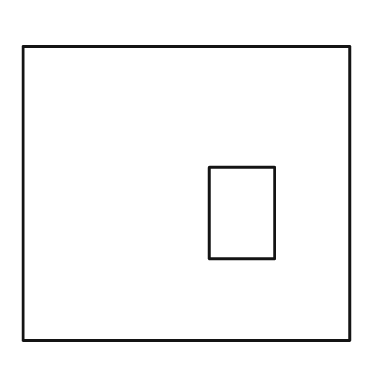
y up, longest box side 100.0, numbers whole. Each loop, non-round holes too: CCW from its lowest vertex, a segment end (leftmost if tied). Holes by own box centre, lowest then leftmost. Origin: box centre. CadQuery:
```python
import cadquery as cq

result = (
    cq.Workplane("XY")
    .moveTo(-50.0, -45.0)
    .lineTo(50.0, -45.0)
    .lineTo(50.0, 45.0)
    .lineTo(-50.0, 45.0)
    .close()
    .moveTo(7.0, -20.0)
    .lineTo(27.0, -20.0)
    .lineTo(27.0, 8.0)
    .lineTo(7.0, 8.0)
    .close()
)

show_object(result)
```